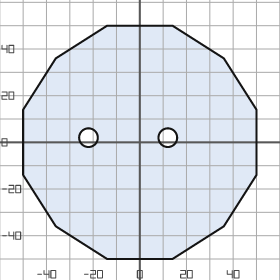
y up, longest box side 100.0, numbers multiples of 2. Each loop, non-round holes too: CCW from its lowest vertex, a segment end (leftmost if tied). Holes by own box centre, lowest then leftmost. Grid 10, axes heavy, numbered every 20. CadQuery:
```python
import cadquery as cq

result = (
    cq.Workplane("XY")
    .moveTo(-14.0, -50.0)
    .lineTo(14.0, -50.0)
    .lineTo(36.0, -36.0)
    .lineTo(50.0, -14.0)
    .lineTo(50.0, 14.0)
    .lineTo(36.0, 36.0)
    .lineTo(14.0, 50.0)
    .lineTo(-14.0, 50.0)
    .lineTo(-36.0, 36.0)
    .lineTo(-50.0, 14.0)
    .lineTo(-50.0, -14.0)
    .lineTo(-36.0, -36.0)
    .close()
    .moveTo(-22.0, 2.0)
    .circle(4.0)
    .moveTo(12.0, 2.0)
    .circle(4.0)
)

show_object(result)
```